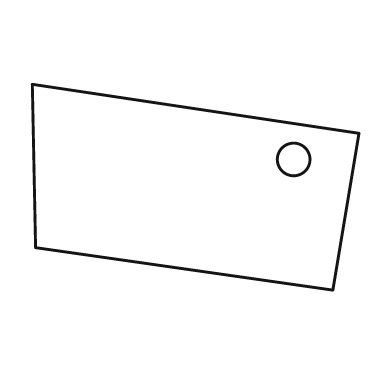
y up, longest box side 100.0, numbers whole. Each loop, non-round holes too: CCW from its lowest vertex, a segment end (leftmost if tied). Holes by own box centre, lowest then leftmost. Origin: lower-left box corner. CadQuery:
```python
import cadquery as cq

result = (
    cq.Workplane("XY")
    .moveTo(92.0, 0.0)
    .lineTo(100.0, 48.0)
    .lineTo(0.0, 63.0)
    .lineTo(1.0, 13.0)
    .close()
    .moveTo(80.0, 40.0)
    .circle(5.0)
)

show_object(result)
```